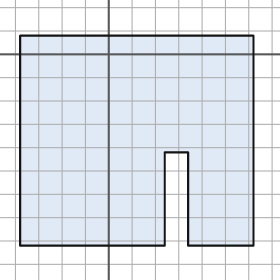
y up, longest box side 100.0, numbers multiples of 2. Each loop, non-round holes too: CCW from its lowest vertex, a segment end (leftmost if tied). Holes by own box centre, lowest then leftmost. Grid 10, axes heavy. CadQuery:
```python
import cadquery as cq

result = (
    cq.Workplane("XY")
    .moveTo(-38.0, -82.0)
    .lineTo(24.0, -82.0)
    .lineTo(24.0, -42.0)
    .lineTo(34.0, -42.0)
    .lineTo(34.0, -82.0)
    .lineTo(62.0, -82.0)
    .lineTo(62.0, 8.0)
    .lineTo(-38.0, 8.0)
    .close()
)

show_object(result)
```